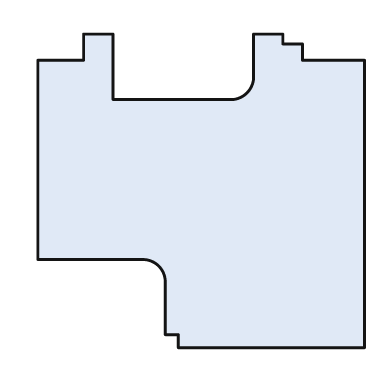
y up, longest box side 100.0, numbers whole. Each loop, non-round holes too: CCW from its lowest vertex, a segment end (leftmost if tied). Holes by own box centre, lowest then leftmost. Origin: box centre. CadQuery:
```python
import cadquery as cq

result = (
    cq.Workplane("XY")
    .moveTo(-7.0, -48.0)
    .lineTo(50.0, -48.0)
    .lineTo(50.0, 40.0)
    .lineTo(31.0, 40.0)
    .lineTo(31.0, 45.0)
    .lineTo(25.0, 45.0)
    .lineTo(25.0, 48.0)
    .lineTo(16.0, 48.0)
    .lineTo(16.0, 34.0)
    .threePointArc((14.0, 30.0), (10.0, 28.0))
    .lineTo(-27.0, 28.0)
    .lineTo(-27.0, 48.0)
    .lineTo(-36.0, 48.0)
    .lineTo(-36.0, 40.0)
    .lineTo(-50.0, 40.0)
    .lineTo(-50.0, -21.0)
    .lineTo(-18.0, -21.0)
    .threePointArc((-13.0, -23.0), (-11.0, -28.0))
    .lineTo(-11.0, -44.0)
    .lineTo(-7.0, -44.0)
    .close()
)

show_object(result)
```